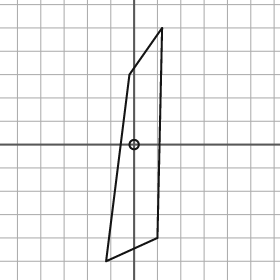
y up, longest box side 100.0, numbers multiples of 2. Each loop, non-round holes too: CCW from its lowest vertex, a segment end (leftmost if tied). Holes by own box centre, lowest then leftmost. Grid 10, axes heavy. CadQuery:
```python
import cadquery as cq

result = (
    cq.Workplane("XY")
    .moveTo(-12.0, -50.0)
    .lineTo(10.0, -40.0)
    .lineTo(12.0, 50.0)
    .lineTo(-2.0, 30.0)
    .close()
    .moveTo(0.0, 0.0)
    .circle(2.0)
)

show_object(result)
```